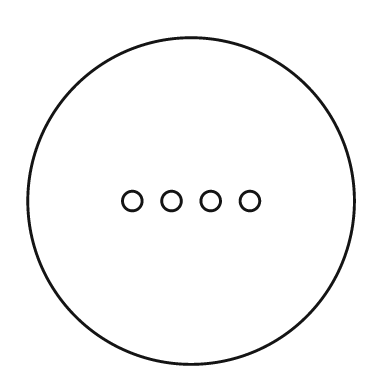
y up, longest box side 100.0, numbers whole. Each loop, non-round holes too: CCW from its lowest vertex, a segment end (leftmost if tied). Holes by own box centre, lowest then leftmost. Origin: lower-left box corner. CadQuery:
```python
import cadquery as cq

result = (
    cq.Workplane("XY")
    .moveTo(50.0, 50.0)
    .circle(50.0)
    .moveTo(32.0, 50.0)
    .circle(3.0)
    .moveTo(44.0, 50.0)
    .circle(3.0)
    .moveTo(56.0, 50.0)
    .circle(3.0)
    .moveTo(68.0, 50.0)
    .circle(3.0)
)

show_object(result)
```